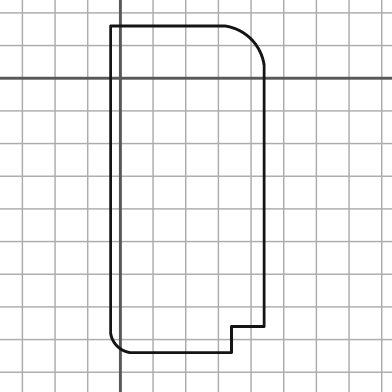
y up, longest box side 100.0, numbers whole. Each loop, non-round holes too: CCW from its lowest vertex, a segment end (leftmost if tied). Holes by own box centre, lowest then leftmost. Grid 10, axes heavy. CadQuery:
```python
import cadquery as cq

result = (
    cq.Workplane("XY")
    .moveTo(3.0, -84.0)
    .lineTo(34.0, -84.0)
    .lineTo(34.0, -76.0)
    .lineTo(44.0, -76.0)
    .lineTo(44.0, 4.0)
    .threePointArc((40.0, 12.0), (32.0, 16.0))
    .lineTo(-3.0, 16.0)
    .lineTo(-3.0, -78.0)
    .threePointArc((-1.0, -82.0), (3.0, -84.0))
    .close()
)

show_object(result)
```